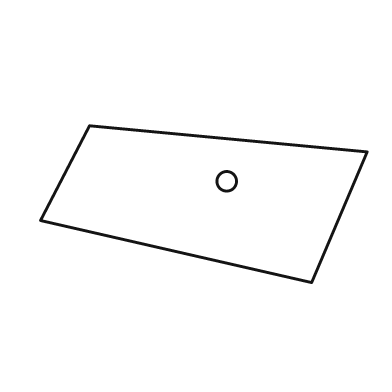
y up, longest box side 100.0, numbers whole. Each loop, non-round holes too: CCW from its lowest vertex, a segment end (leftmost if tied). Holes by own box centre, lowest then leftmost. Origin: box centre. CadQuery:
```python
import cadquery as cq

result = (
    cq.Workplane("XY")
    .moveTo(33.0, -24.0)
    .lineTo(50.0, 16.0)
    .lineTo(-35.0, 24.0)
    .lineTo(-50.0, -5.0)
    .close()
    .moveTo(7.0, 7.0)
    .circle(3.0)
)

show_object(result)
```